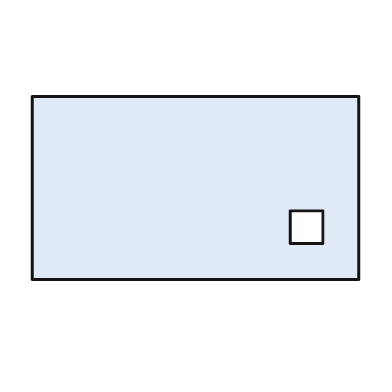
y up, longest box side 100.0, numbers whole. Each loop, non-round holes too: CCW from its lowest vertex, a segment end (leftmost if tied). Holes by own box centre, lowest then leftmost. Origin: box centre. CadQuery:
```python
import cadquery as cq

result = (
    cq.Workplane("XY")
    .moveTo(-50.0, -28.0)
    .lineTo(50.0, -28.0)
    .lineTo(50.0, 28.0)
    .lineTo(-50.0, 28.0)
    .close()
    .moveTo(29.0, -17.0)
    .lineTo(39.0, -17.0)
    .lineTo(39.0, -7.0)
    .lineTo(29.0, -7.0)
    .close()
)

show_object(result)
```